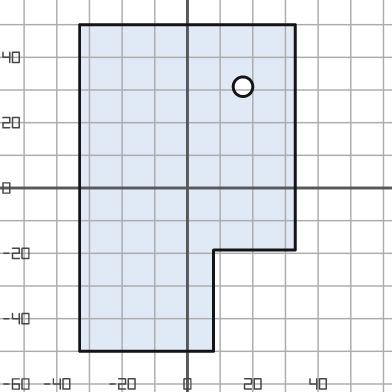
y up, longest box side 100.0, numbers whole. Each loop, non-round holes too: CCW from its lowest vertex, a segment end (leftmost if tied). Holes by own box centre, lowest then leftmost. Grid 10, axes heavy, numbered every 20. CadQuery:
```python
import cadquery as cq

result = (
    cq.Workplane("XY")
    .moveTo(-33.0, -50.0)
    .lineTo(8.0, -50.0)
    .lineTo(8.0, -19.0)
    .lineTo(33.0, -19.0)
    .lineTo(33.0, 50.0)
    .lineTo(-33.0, 50.0)
    .close()
    .moveTo(17.0, 31.0)
    .circle(3.0)
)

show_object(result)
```